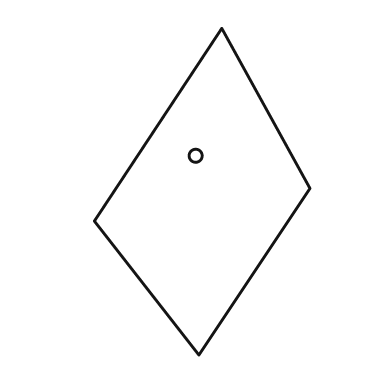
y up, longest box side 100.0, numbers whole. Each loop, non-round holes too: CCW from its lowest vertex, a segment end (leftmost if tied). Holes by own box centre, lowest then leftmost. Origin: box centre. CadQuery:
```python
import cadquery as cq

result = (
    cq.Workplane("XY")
    .moveTo(-1.0, -50.0)
    .lineTo(33.0, 1.0)
    .lineTo(6.0, 50.0)
    .lineTo(-33.0, -9.0)
    .close()
    .moveTo(-2.0, 11.0)
    .circle(2.0)
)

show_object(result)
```